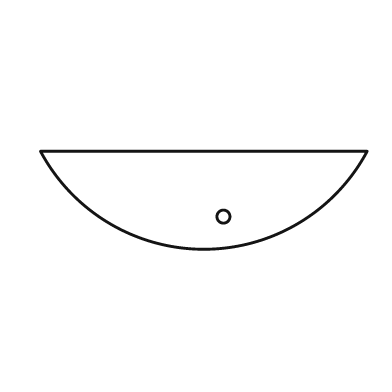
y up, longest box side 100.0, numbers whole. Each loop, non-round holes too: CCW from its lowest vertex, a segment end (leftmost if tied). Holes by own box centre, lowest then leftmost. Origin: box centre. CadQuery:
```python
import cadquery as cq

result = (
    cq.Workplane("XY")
    .moveTo(-50.0, 15.0)
    .threePointArc((0.0, -15.0), (50.0, 15.0))
    .close()
    .moveTo(6.0, -5.0)
    .circle(2.0)
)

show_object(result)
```